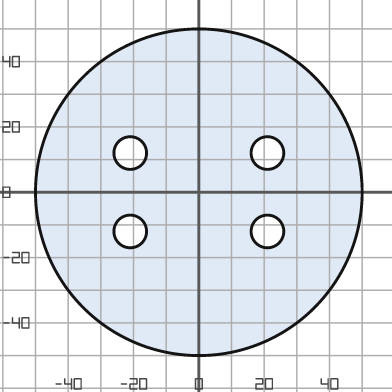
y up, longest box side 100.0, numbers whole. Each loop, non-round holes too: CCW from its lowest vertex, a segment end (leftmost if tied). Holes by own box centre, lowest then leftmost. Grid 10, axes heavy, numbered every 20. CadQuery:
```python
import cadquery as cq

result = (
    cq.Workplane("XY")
    .moveTo(0.0, 0.0)
    .circle(50.0)
    .moveTo(-21.0, -12.0)
    .circle(5.0)
    .moveTo(21.0, -12.0)
    .circle(5.0)
    .moveTo(-21.0, 12.0)
    .circle(5.0)
    .moveTo(21.0, 12.0)
    .circle(5.0)
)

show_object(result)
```